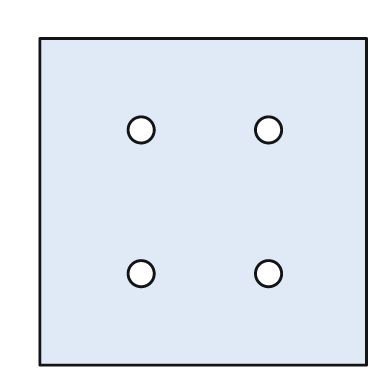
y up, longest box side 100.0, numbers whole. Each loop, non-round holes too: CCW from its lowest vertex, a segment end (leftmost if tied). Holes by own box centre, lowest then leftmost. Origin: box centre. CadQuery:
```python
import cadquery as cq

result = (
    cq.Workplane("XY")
    .moveTo(-50.0, -50.0)
    .lineTo(50.0, -50.0)
    .lineTo(50.0, 50.0)
    .lineTo(-50.0, 50.0)
    .close()
    .moveTo(-19.0, -22.0)
    .circle(4.0)
    .moveTo(20.0, -22.0)
    .circle(4.0)
    .moveTo(-19.0, 22.0)
    .circle(4.0)
    .moveTo(20.0, 22.0)
    .circle(4.0)
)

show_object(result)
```